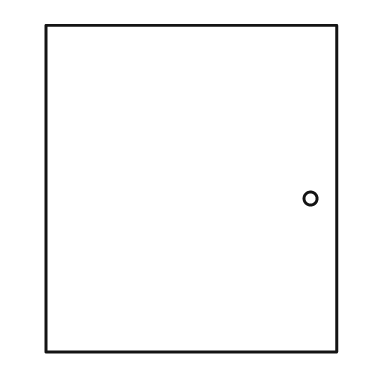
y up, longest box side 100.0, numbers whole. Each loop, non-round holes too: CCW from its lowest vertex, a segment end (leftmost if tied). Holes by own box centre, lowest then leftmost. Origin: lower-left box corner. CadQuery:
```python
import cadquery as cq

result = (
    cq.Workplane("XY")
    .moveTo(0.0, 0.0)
    .lineTo(89.0, 0.0)
    .lineTo(89.0, 100.0)
    .lineTo(0.0, 100.0)
    .close()
    .moveTo(81.0, 47.0)
    .circle(2.0)
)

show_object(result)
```